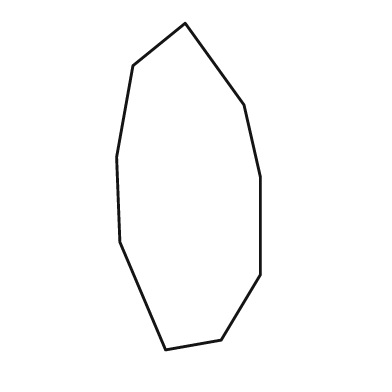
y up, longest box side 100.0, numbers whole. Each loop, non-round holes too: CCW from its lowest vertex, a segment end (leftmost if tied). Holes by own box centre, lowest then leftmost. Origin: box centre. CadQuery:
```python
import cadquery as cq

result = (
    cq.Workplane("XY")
    .moveTo(-7.0, -50.0)
    .lineTo(10.0, -47.0)
    .lineTo(22.0, -27.0)
    .lineTo(22.0, 3.0)
    .lineTo(17.0, 25.0)
    .lineTo(-1.0, 50.0)
    .lineTo(-17.0, 37.0)
    .lineTo(-22.0, 9.0)
    .lineTo(-21.0, -17.0)
    .close()
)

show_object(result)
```